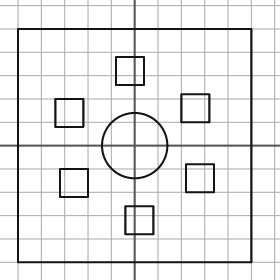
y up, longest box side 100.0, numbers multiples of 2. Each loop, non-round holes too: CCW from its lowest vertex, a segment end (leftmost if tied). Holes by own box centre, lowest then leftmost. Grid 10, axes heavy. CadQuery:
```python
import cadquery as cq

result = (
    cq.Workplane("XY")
    .moveTo(-50.0, -50.0)
    .lineTo(50.0, -50.0)
    .lineTo(50.0, 50.0)
    .lineTo(-50.0, 50.0)
    .close()
    .moveTo(-4.0, -38.0)
    .lineTo(8.0, -38.0)
    .lineTo(8.0, -26.0)
    .lineTo(-4.0, -26.0)
    .close()
    .moveTo(-32.0, -22.0)
    .lineTo(-20.0, -22.0)
    .lineTo(-20.0, -10.0)
    .lineTo(-32.0, -10.0)
    .close()
    .moveTo(22.0, -20.0)
    .lineTo(34.0, -20.0)
    .lineTo(34.0, -8.0)
    .lineTo(22.0, -8.0)
    .close()
    .moveTo(0.0, 0.0)
    .circle(14.0)
    .moveTo(-34.0, 8.0)
    .lineTo(-22.0, 8.0)
    .lineTo(-22.0, 20.0)
    .lineTo(-34.0, 20.0)
    .close()
    .moveTo(20.0, 10.0)
    .lineTo(32.0, 10.0)
    .lineTo(32.0, 22.0)
    .lineTo(20.0, 22.0)
    .close()
    .moveTo(-8.0, 26.0)
    .lineTo(4.0, 26.0)
    .lineTo(4.0, 38.0)
    .lineTo(-8.0, 38.0)
    .close()
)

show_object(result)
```